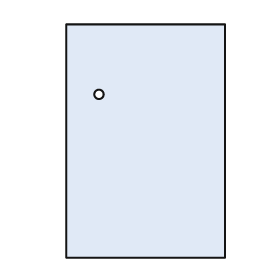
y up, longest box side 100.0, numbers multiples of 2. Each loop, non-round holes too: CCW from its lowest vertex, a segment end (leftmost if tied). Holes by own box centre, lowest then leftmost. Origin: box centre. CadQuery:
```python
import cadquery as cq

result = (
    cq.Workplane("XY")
    .moveTo(-34.0, -50.0)
    .lineTo(34.0, -50.0)
    .lineTo(34.0, 50.0)
    .lineTo(-34.0, 50.0)
    .close()
    .moveTo(-20.0, 20.0)
    .circle(2.0)
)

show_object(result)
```